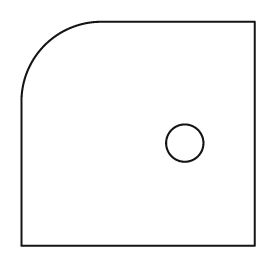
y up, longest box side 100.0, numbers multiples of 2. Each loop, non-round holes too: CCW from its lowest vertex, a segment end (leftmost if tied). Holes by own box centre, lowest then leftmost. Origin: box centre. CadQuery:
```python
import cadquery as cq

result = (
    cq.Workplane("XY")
    .moveTo(-50.0, -48.0)
    .lineTo(50.0, -48.0)
    .lineTo(50.0, 48.0)
    .lineTo(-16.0, 48.0)
    .threePointArc((-40.0, 38.0), (-50.0, 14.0))
    .close()
    .moveTo(20.0, -4.0)
    .circle(8.0)
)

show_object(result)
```